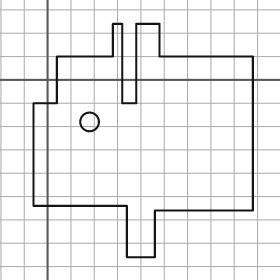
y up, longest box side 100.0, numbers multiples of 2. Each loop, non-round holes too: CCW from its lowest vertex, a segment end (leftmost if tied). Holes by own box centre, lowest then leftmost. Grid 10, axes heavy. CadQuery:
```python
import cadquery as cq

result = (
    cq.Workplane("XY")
    .moveTo(34.0, -76.0)
    .lineTo(46.0, -76.0)
    .lineTo(46.0, -56.0)
    .lineTo(88.0, -56.0)
    .lineTo(88.0, 10.0)
    .lineTo(48.0, 10.0)
    .lineTo(48.0, 24.0)
    .lineTo(38.0, 24.0)
    .lineTo(38.0, -10.0)
    .lineTo(32.0, -10.0)
    .lineTo(32.0, 24.0)
    .lineTo(28.0, 24.0)
    .lineTo(28.0, 10.0)
    .lineTo(4.0, 10.0)
    .lineTo(4.0, -10.0)
    .lineTo(-6.0, -10.0)
    .lineTo(-6.0, -54.0)
    .lineTo(34.0, -54.0)
    .close()
    .moveTo(18.0, -18.0)
    .circle(4.0)
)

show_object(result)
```